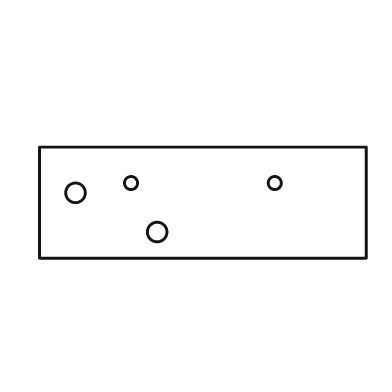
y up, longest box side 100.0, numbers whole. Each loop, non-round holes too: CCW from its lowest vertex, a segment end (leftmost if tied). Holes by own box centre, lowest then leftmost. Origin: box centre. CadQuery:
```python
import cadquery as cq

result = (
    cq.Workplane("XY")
    .moveTo(-50.0, -17.0)
    .lineTo(50.0, -17.0)
    .lineTo(50.0, 17.0)
    .lineTo(-50.0, 17.0)
    .close()
    .moveTo(-14.0, -9.0)
    .circle(3.0)
    .moveTo(-39.0, 3.0)
    .circle(3.0)
    .moveTo(-22.0, 6.0)
    .circle(2.0)
    .moveTo(22.0, 6.0)
    .circle(2.0)
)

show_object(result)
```